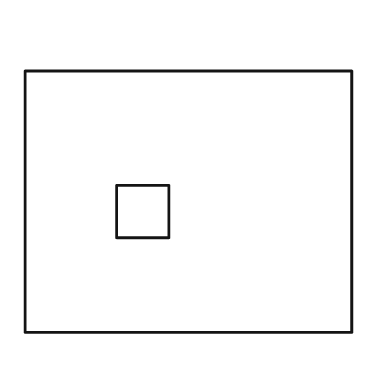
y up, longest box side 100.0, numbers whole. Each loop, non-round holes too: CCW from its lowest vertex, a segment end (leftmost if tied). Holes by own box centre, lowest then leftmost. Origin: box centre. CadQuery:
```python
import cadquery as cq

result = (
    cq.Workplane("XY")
    .moveTo(-50.0, -40.0)
    .lineTo(50.0, -40.0)
    .lineTo(50.0, 40.0)
    .lineTo(-50.0, 40.0)
    .close()
    .moveTo(-22.0, -11.0)
    .lineTo(-6.0, -11.0)
    .lineTo(-6.0, 5.0)
    .lineTo(-22.0, 5.0)
    .close()
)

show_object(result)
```